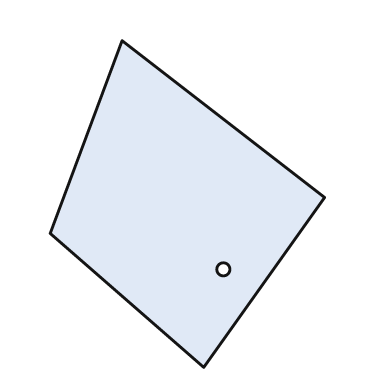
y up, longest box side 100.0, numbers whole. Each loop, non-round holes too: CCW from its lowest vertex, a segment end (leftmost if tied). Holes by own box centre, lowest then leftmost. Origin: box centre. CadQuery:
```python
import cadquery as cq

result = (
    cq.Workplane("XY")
    .moveTo(5.0, -50.0)
    .lineTo(42.0, 2.0)
    .lineTo(-20.0, 50.0)
    .lineTo(-42.0, -9.0)
    .close()
    .moveTo(11.0, -20.0)
    .circle(2.0)
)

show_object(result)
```